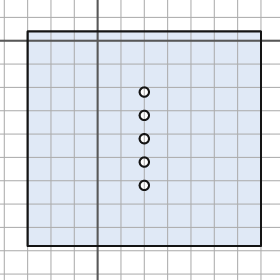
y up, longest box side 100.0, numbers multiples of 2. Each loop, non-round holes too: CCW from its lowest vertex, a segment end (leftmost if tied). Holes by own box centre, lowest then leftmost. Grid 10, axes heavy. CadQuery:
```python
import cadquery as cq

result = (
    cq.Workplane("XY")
    .moveTo(-30.0, -88.0)
    .lineTo(70.0, -88.0)
    .lineTo(70.0, 4.0)
    .lineTo(-30.0, 4.0)
    .close()
    .moveTo(20.0, -62.0)
    .circle(2.0)
    .moveTo(20.0, -52.0)
    .circle(2.0)
    .moveTo(20.0, -42.0)
    .circle(2.0)
    .moveTo(20.0, -32.0)
    .circle(2.0)
    .moveTo(20.0, -22.0)
    .circle(2.0)
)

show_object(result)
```